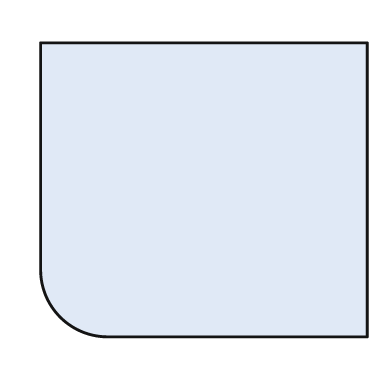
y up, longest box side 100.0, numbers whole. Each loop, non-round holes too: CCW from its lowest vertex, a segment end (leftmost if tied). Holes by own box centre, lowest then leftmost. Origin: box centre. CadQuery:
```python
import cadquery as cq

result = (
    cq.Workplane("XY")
    .moveTo(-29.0, -45.0)
    .lineTo(50.0, -45.0)
    .lineTo(50.0, 45.0)
    .lineTo(-50.0, 45.0)
    .lineTo(-50.0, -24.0)
    .threePointArc((-44.0, -39.0), (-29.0, -45.0))
    .close()
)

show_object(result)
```